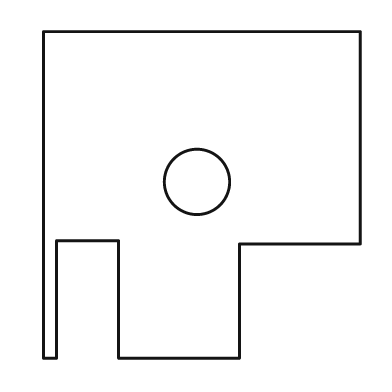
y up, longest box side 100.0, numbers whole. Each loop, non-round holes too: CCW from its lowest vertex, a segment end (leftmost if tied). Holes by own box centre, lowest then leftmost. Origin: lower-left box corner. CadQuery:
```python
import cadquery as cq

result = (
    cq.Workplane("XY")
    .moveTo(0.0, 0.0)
    .lineTo(4.0, 0.0)
    .lineTo(4.0, 36.0)
    .lineTo(23.0, 36.0)
    .lineTo(23.0, 0.0)
    .lineTo(60.0, 0.0)
    .lineTo(60.0, 35.0)
    .lineTo(97.0, 35.0)
    .lineTo(97.0, 100.0)
    .lineTo(0.0, 100.0)
    .close()
    .moveTo(47.0, 54.0)
    .circle(10.0)
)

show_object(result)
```